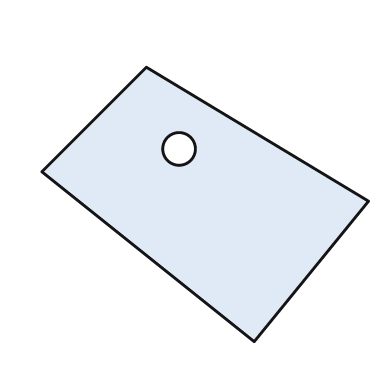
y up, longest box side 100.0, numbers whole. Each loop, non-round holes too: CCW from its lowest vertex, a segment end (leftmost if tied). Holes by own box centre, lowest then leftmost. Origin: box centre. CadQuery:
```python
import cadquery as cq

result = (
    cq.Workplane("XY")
    .moveTo(15.0, -42.0)
    .lineTo(50.0, 1.0)
    .lineTo(-18.0, 42.0)
    .lineTo(-50.0, 10.0)
    .close()
    .moveTo(-8.0, 17.0)
    .circle(5.0)
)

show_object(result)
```